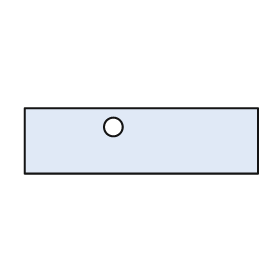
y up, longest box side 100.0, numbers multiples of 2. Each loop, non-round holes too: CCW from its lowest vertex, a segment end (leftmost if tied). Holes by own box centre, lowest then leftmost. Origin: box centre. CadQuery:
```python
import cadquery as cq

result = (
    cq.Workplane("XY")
    .moveTo(-50.0, -14.0)
    .lineTo(50.0, -14.0)
    .lineTo(50.0, 14.0)
    .lineTo(-50.0, 14.0)
    .close()
    .moveTo(-12.0, 6.0)
    .circle(4.0)
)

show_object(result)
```